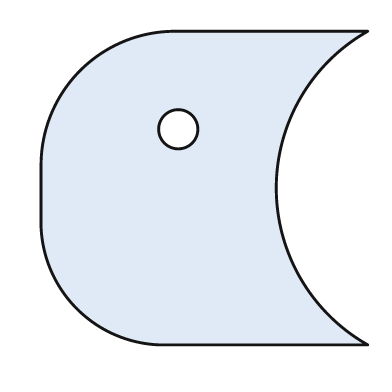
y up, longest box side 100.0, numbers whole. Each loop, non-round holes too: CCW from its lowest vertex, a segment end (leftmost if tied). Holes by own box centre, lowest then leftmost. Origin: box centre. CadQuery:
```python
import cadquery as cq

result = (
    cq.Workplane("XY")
    .moveTo(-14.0, -48.0)
    .lineTo(50.0, -48.0)
    .threePointArc((22.0, 0.0), (50.0, 48.0))
    .lineTo(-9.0, 48.0)
    .threePointArc((-38.0, 36.0), (-50.0, 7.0))
    .lineTo(-50.0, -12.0)
    .threePointArc((-39.0, -37.0), (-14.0, -48.0))
    .close()
    .moveTo(-8.0, 18.0)
    .circle(6.0)
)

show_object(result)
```